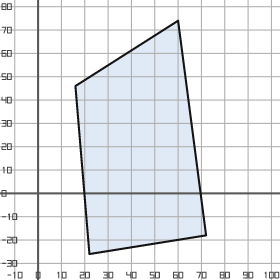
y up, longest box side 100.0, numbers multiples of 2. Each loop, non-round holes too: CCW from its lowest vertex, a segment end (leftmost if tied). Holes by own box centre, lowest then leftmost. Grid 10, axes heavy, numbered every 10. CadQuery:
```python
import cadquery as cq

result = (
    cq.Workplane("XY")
    .moveTo(22.0, -26.0)
    .lineTo(72.0, -18.0)
    .lineTo(60.0, 74.0)
    .lineTo(16.0, 46.0)
    .close()
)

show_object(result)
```